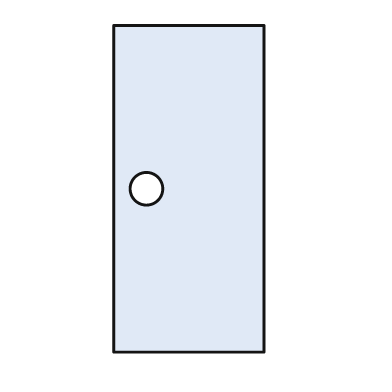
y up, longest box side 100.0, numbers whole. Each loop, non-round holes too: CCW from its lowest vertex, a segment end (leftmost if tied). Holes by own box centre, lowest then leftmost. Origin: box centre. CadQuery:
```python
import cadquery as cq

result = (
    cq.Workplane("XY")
    .moveTo(-23.0, -50.0)
    .lineTo(23.0, -50.0)
    .lineTo(23.0, 50.0)
    .lineTo(-23.0, 50.0)
    .close()
    .moveTo(-13.0, 0.0)
    .circle(5.0)
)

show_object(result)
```